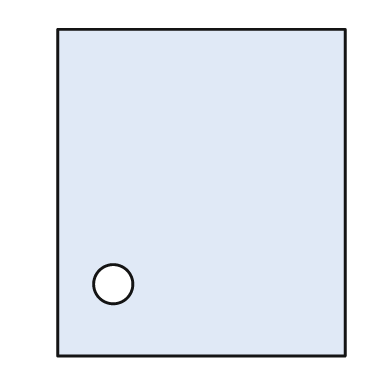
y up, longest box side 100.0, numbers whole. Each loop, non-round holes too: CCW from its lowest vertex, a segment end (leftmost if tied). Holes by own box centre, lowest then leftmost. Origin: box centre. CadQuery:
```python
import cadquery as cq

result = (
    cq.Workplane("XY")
    .moveTo(-44.0, -50.0)
    .lineTo(44.0, -50.0)
    .lineTo(44.0, 50.0)
    .lineTo(-44.0, 50.0)
    .close()
    .moveTo(-27.0, -28.0)
    .circle(6.0)
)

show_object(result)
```